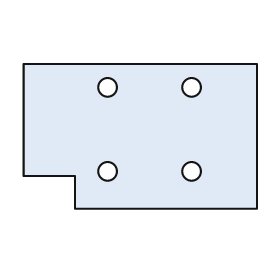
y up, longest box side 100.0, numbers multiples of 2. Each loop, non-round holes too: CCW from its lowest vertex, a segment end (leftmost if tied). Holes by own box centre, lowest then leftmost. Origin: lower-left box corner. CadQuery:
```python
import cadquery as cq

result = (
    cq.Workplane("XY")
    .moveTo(22.0, 0.0)
    .lineTo(100.0, 0.0)
    .lineTo(100.0, 62.0)
    .lineTo(0.0, 62.0)
    .lineTo(0.0, 14.0)
    .lineTo(22.0, 14.0)
    .close()
    .moveTo(36.0, 16.0)
    .circle(4.0)
    .moveTo(72.0, 16.0)
    .circle(4.0)
    .moveTo(36.0, 52.0)
    .circle(4.0)
    .moveTo(72.0, 52.0)
    .circle(4.0)
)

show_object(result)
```